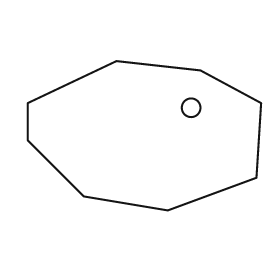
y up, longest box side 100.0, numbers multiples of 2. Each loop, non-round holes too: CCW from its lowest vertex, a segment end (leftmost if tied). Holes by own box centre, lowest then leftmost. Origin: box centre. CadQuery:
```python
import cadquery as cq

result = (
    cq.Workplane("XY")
    .moveTo(10.0, -32.0)
    .lineTo(48.0, -18.0)
    .lineTo(50.0, 14.0)
    .lineTo(24.0, 28.0)
    .lineTo(-12.0, 32.0)
    .lineTo(-50.0, 14.0)
    .lineTo(-50.0, -2.0)
    .lineTo(-26.0, -26.0)
    .close()
    .moveTo(20.0, 12.0)
    .circle(4.0)
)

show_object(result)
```